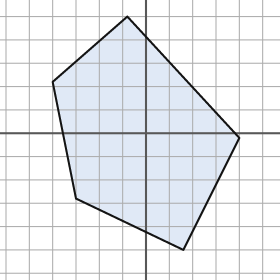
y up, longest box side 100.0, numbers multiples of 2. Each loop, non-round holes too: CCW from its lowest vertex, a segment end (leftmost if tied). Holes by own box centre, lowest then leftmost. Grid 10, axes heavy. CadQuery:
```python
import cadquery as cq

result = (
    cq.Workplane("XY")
    .moveTo(16.0, -50.0)
    .lineTo(40.0, -2.0)
    .lineTo(-8.0, 50.0)
    .lineTo(-40.0, 22.0)
    .lineTo(-30.0, -28.0)
    .close()
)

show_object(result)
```